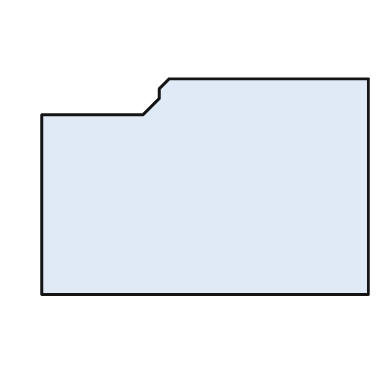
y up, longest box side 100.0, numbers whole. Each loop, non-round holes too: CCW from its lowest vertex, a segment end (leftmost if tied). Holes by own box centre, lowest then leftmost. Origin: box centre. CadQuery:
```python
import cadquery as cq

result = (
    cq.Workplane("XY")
    .moveTo(-50.0, -33.0)
    .lineTo(50.0, -33.0)
    .lineTo(50.0, 33.0)
    .lineTo(-11.0, 33.0)
    .lineTo(-14.0, 30.0)
    .lineTo(-14.0, 27.0)
    .lineTo(-19.0, 22.0)
    .lineTo(-50.0, 22.0)
    .close()
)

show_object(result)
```